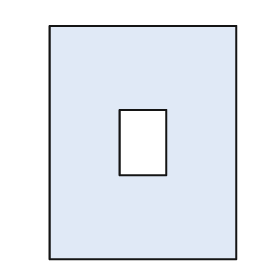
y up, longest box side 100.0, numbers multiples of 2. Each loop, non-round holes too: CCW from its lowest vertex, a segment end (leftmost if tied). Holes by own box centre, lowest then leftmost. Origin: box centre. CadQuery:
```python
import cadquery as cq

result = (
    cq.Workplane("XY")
    .moveTo(-40.0, -50.0)
    .lineTo(40.0, -50.0)
    .lineTo(40.0, 50.0)
    .lineTo(-40.0, 50.0)
    .close()
    .moveTo(-10.0, -14.0)
    .lineTo(10.0, -14.0)
    .lineTo(10.0, 14.0)
    .lineTo(-10.0, 14.0)
    .close()
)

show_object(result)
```